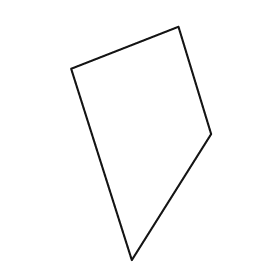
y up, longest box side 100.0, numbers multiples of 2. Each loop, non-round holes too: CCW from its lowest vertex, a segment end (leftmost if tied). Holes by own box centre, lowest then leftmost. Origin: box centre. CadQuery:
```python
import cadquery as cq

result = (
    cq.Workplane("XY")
    .moveTo(-4.0, -50.0)
    .lineTo(30.0, 4.0)
    .lineTo(16.0, 50.0)
    .lineTo(-30.0, 32.0)
    .close()
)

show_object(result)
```